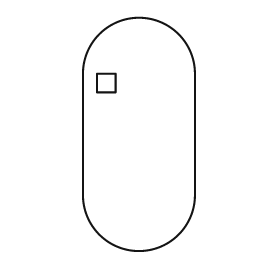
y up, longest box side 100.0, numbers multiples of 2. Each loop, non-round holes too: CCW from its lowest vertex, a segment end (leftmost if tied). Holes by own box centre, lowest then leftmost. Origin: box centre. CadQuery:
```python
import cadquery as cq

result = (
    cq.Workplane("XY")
    .moveTo(-24.0, -26.0)
    .threePointArc((0.0, -50.0), (24.0, -26.0))
    .lineTo(24.0, 26.0)
    .threePointArc((0.0, 50.0), (-24.0, 26.0))
    .close()
    .moveTo(-18.0, 18.0)
    .lineTo(-10.0, 18.0)
    .lineTo(-10.0, 26.0)
    .lineTo(-18.0, 26.0)
    .close()
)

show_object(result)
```